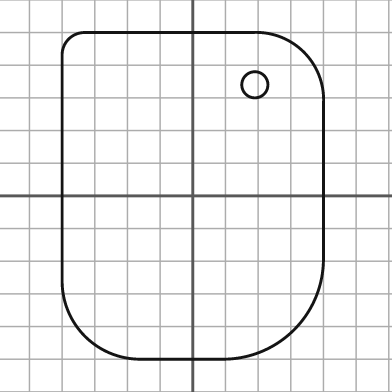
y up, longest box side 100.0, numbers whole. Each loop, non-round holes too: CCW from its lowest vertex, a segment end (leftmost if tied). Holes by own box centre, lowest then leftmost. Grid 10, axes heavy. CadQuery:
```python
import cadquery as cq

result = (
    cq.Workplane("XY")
    .moveTo(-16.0, -50.0)
    .lineTo(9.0, -50.0)
    .threePointArc((31.0, -41.0), (40.0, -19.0))
    .lineTo(40.0, 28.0)
    .threePointArc((34.0, 44.0), (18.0, 50.0))
    .lineTo(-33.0, 50.0)
    .threePointArc((-38.0, 48.0), (-40.0, 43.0))
    .lineTo(-40.0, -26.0)
    .threePointArc((-33.0, -43.0), (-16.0, -50.0))
    .close()
    .moveTo(19.0, 34.0)
    .circle(4.0)
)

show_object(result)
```